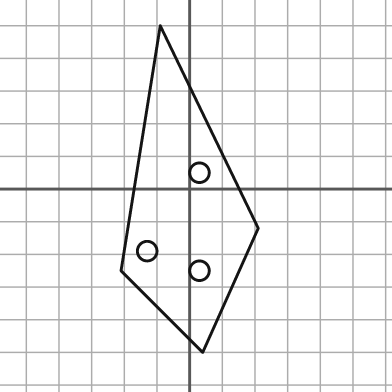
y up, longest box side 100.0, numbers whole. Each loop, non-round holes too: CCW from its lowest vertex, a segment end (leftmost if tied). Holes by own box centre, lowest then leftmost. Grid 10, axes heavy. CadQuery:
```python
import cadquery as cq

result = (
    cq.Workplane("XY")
    .moveTo(4.0, -50.0)
    .lineTo(21.0, -12.0)
    .lineTo(-9.0, 50.0)
    .lineTo(-21.0, -25.0)
    .close()
    .moveTo(3.0, -25.0)
    .circle(3.0)
    .moveTo(-13.0, -19.0)
    .circle(3.0)
    .moveTo(3.0, 5.0)
    .circle(3.0)
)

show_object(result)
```